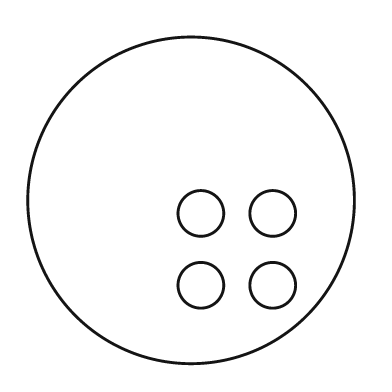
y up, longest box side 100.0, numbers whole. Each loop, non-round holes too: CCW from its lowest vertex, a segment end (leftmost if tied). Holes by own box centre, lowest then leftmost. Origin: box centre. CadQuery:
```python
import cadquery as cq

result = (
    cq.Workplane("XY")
    .moveTo(0.0, 0.0)
    .circle(50.0)
    .moveTo(3.0, -26.0)
    .circle(7.0)
    .moveTo(25.0, -26.0)
    .circle(7.0)
    .moveTo(3.0, -4.0)
    .circle(7.0)
    .moveTo(25.0, -4.0)
    .circle(7.0)
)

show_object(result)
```